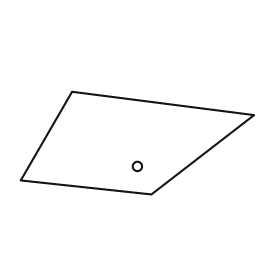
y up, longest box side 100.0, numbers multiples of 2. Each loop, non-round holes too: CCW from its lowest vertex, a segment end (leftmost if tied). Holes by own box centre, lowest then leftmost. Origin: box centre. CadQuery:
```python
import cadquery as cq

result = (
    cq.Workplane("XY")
    .moveTo(6.0, -22.0)
    .lineTo(50.0, 12.0)
    .lineTo(-28.0, 22.0)
    .lineTo(-50.0, -16.0)
    .close()
    .moveTo(0.0, -10.0)
    .circle(2.0)
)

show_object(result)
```